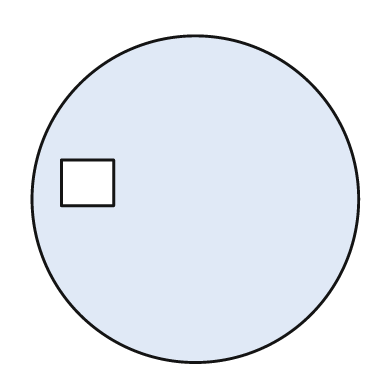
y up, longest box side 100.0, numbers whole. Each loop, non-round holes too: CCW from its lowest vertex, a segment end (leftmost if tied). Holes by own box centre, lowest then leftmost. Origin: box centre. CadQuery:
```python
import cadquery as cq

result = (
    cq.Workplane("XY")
    .moveTo(0.0, 0.0)
    .circle(50.0)
    .moveTo(-41.0, -2.0)
    .lineTo(-25.0, -2.0)
    .lineTo(-25.0, 12.0)
    .lineTo(-41.0, 12.0)
    .close()
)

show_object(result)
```